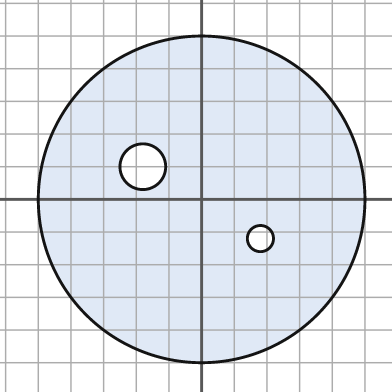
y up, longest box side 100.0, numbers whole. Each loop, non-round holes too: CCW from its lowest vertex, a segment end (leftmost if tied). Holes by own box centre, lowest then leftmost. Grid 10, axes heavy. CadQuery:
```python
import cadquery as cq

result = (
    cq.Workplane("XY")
    .moveTo(0.0, 0.0)
    .circle(50.0)
    .moveTo(18.0, -12.0)
    .circle(4.0)
    .moveTo(-18.0, 10.0)
    .circle(7.0)
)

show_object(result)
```